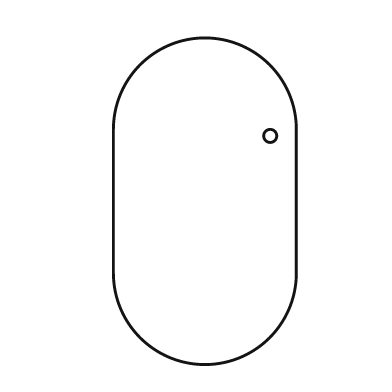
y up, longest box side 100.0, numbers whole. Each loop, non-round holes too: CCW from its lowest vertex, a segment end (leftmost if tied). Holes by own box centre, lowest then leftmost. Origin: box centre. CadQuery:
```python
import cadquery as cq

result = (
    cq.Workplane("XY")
    .moveTo(-28.0, -22.0)
    .threePointArc((0.0, -50.0), (28.0, -22.0))
    .lineTo(28.0, 22.0)
    .threePointArc((0.0, 50.0), (-28.0, 22.0))
    .close()
    .moveTo(20.0, 20.0)
    .circle(2.0)
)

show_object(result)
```